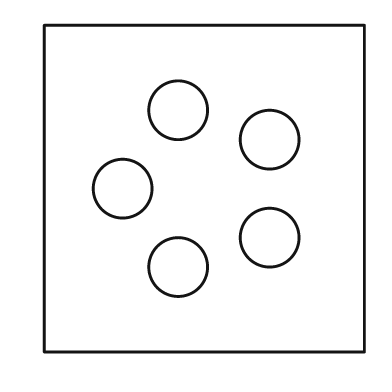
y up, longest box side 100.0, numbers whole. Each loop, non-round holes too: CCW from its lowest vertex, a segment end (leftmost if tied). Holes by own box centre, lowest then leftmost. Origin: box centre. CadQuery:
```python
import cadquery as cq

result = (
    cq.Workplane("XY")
    .moveTo(-49.0, -50.0)
    .lineTo(49.0, -50.0)
    .lineTo(49.0, 50.0)
    .lineTo(-49.0, 50.0)
    .close()
    .moveTo(-8.0, -24.0)
    .circle(9.0)
    .moveTo(20.0, -15.0)
    .circle(9.0)
    .moveTo(-25.0, 0.0)
    .circle(9.0)
    .moveTo(20.0, 15.0)
    .circle(9.0)
    .moveTo(-8.0, 24.0)
    .circle(9.0)
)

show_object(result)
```